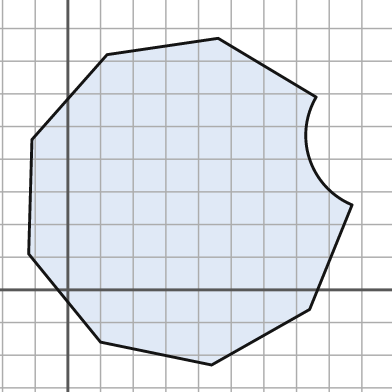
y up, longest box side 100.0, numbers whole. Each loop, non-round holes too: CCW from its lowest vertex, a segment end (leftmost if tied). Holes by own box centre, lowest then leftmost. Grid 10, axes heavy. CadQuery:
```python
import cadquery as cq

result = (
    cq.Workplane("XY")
    .moveTo(44.0, -23.0)
    .lineTo(74.0, -6.0)
    .lineTo(87.0, 26.0)
    .threePointArc((74.0, 40.0), (76.0, 59.0))
    .lineTo(46.0, 77.0)
    .lineTo(12.0, 72.0)
    .lineTo(-11.0, 46.0)
    .lineTo(-12.0, 11.0)
    .lineTo(10.0, -16.0)
    .close()
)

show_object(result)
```